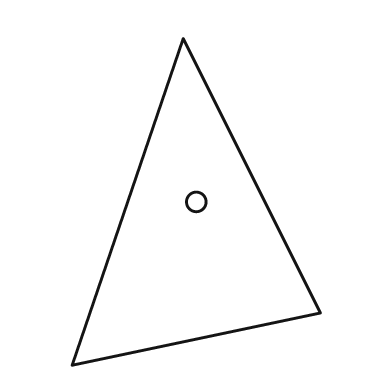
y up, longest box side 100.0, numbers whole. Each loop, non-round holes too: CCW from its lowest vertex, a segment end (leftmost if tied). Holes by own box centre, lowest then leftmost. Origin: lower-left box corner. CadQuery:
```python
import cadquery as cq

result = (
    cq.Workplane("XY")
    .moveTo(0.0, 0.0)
    .lineTo(76.0, 16.0)
    .lineTo(34.0, 100.0)
    .close()
    .moveTo(38.0, 50.0)
    .circle(3.0)
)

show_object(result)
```